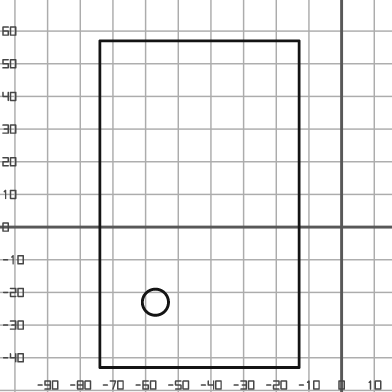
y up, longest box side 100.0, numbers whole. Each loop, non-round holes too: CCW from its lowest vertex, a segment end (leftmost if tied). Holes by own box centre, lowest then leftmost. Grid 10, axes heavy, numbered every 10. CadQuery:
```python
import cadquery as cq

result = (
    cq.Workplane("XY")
    .moveTo(-74.0, -43.0)
    .lineTo(-13.0, -43.0)
    .lineTo(-13.0, 57.0)
    .lineTo(-74.0, 57.0)
    .close()
    .moveTo(-57.0, -23.0)
    .circle(4.0)
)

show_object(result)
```